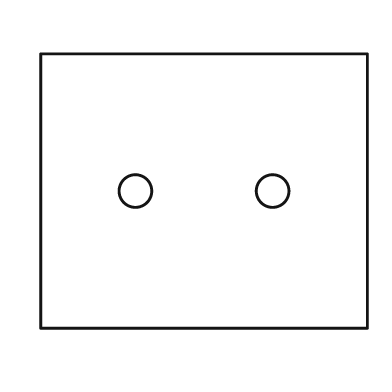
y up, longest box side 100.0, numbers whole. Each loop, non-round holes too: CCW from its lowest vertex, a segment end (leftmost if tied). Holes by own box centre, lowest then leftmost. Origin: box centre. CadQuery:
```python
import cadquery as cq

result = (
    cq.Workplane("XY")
    .moveTo(-50.0, -42.0)
    .lineTo(50.0, -42.0)
    .lineTo(50.0, 42.0)
    .lineTo(-50.0, 42.0)
    .close()
    .moveTo(-21.0, 0.0)
    .circle(5.0)
    .moveTo(21.0, 0.0)
    .circle(5.0)
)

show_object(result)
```